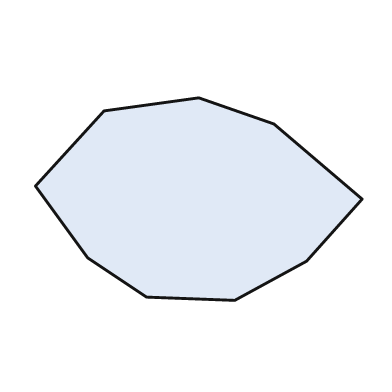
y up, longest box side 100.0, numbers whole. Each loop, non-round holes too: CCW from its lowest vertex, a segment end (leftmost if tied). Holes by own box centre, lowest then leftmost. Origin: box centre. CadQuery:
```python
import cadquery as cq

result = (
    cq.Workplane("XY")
    .moveTo(11.0, -31.0)
    .lineTo(33.0, -19.0)
    .lineTo(50.0, 0.0)
    .lineTo(23.0, 23.0)
    .lineTo(0.0, 31.0)
    .lineTo(-29.0, 27.0)
    .lineTo(-50.0, 4.0)
    .lineTo(-34.0, -18.0)
    .lineTo(-16.0, -30.0)
    .close()
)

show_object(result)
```